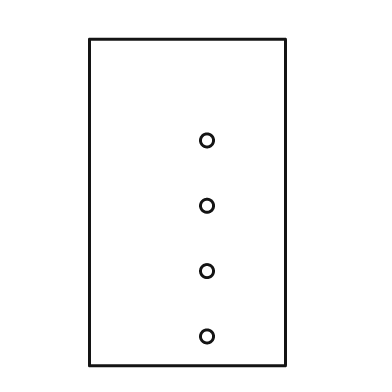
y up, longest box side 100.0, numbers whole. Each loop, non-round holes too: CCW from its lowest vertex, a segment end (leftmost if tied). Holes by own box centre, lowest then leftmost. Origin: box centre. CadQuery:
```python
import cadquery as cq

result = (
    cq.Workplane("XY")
    .moveTo(-30.0, -50.0)
    .lineTo(30.0, -50.0)
    .lineTo(30.0, 50.0)
    .lineTo(-30.0, 50.0)
    .close()
    .moveTo(6.0, -41.0)
    .circle(2.0)
    .moveTo(6.0, -21.0)
    .circle(2.0)
    .moveTo(6.0, -1.0)
    .circle(2.0)
    .moveTo(6.0, 19.0)
    .circle(2.0)
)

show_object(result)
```